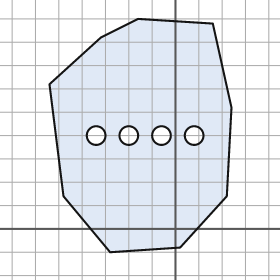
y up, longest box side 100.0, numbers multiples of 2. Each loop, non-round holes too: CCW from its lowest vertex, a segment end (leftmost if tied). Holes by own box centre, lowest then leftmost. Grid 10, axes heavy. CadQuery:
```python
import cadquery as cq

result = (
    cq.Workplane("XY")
    .moveTo(-28.0, -10.0)
    .lineTo(2.0, -8.0)
    .lineTo(22.0, 14.0)
    .lineTo(24.0, 52.0)
    .lineTo(16.0, 88.0)
    .lineTo(-16.0, 90.0)
    .lineTo(-32.0, 82.0)
    .lineTo(-54.0, 62.0)
    .lineTo(-48.0, 14.0)
    .close()
    .moveTo(-34.0, 40.0)
    .circle(4.0)
    .moveTo(-20.0, 40.0)
    .circle(4.0)
    .moveTo(-6.0, 40.0)
    .circle(4.0)
    .moveTo(8.0, 40.0)
    .circle(4.0)
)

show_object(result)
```